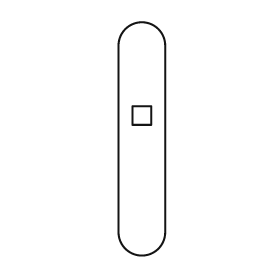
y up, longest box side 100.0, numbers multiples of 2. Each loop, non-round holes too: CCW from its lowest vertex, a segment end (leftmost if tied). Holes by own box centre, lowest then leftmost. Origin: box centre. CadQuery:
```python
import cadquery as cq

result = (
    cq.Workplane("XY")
    .moveTo(-10.0, -40.0)
    .threePointArc((0.0, -50.0), (10.0, -40.0))
    .lineTo(10.0, 40.0)
    .threePointArc((0.0, 50.0), (-10.0, 40.0))
    .close()
    .moveTo(-4.0, 6.0)
    .lineTo(4.0, 6.0)
    .lineTo(4.0, 14.0)
    .lineTo(-4.0, 14.0)
    .close()
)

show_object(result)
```